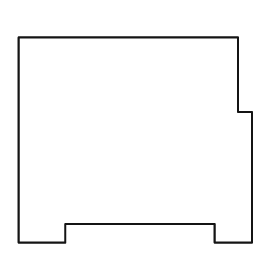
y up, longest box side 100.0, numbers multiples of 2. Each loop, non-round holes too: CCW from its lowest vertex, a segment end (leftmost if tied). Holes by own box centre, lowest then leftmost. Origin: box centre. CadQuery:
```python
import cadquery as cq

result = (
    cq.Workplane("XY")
    .moveTo(-50.0, -44.0)
    .lineTo(-30.0, -44.0)
    .lineTo(-30.0, -36.0)
    .lineTo(34.0, -36.0)
    .lineTo(34.0, -44.0)
    .lineTo(50.0, -44.0)
    .lineTo(50.0, 12.0)
    .lineTo(44.0, 12.0)
    .lineTo(44.0, 44.0)
    .lineTo(-50.0, 44.0)
    .close()
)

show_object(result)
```